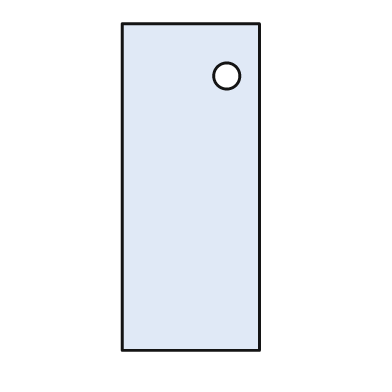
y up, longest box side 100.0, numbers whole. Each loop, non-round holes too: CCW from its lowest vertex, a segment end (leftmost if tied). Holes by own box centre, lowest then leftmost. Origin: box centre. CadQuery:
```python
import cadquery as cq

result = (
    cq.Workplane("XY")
    .moveTo(-21.0, -50.0)
    .lineTo(21.0, -50.0)
    .lineTo(21.0, 50.0)
    .lineTo(-21.0, 50.0)
    .close()
    .moveTo(11.0, 34.0)
    .circle(4.0)
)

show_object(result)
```